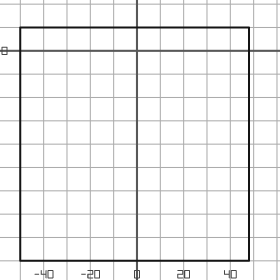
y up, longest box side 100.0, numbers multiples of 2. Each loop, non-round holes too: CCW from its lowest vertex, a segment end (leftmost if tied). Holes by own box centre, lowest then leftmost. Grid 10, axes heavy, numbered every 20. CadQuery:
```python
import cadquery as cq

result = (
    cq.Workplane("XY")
    .moveTo(-50.0, -90.0)
    .lineTo(48.0, -90.0)
    .lineTo(48.0, 10.0)
    .lineTo(-50.0, 10.0)
    .close()
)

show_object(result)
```